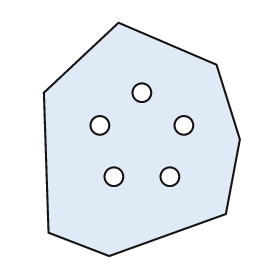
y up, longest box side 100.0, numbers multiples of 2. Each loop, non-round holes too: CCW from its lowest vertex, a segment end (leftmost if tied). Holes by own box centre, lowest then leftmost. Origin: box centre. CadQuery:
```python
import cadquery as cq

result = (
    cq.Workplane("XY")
    .moveTo(-14.0, -50.0)
    .lineTo(36.0, -32.0)
    .lineTo(42.0, 0.0)
    .lineTo(32.0, 32.0)
    .lineTo(-10.0, 50.0)
    .lineTo(-42.0, 20.0)
    .lineTo(-40.0, -40.0)
    .close()
    .moveTo(-12.0, -16.0)
    .circle(4.0)
    .moveTo(12.0, -16.0)
    .circle(4.0)
    .moveTo(-18.0, 6.0)
    .circle(4.0)
    .moveTo(18.0, 6.0)
    .circle(4.0)
    .moveTo(0.0, 20.0)
    .circle(4.0)
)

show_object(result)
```